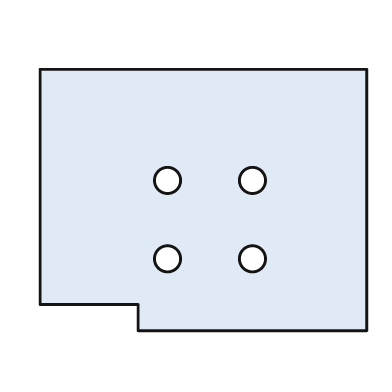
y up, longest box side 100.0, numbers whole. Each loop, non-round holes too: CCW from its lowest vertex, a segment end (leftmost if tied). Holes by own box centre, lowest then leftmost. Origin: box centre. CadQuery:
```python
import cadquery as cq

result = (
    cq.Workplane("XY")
    .moveTo(-20.0, -40.0)
    .lineTo(50.0, -40.0)
    .lineTo(50.0, 40.0)
    .lineTo(-50.0, 40.0)
    .lineTo(-50.0, -32.0)
    .lineTo(-20.0, -32.0)
    .close()
    .moveTo(-11.0, -18.0)
    .circle(4.0)
    .moveTo(15.0, -18.0)
    .circle(4.0)
    .moveTo(-11.0, 6.0)
    .circle(4.0)
    .moveTo(15.0, 6.0)
    .circle(4.0)
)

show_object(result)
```